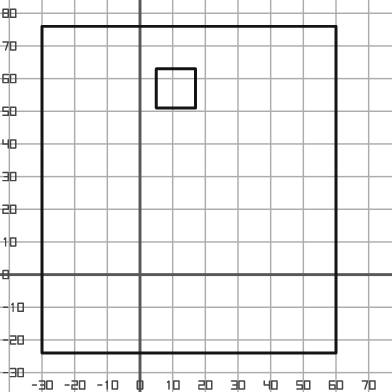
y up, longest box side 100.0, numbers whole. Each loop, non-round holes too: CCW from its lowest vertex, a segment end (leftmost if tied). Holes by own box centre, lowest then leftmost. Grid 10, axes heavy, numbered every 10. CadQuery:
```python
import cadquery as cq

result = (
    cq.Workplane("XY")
    .moveTo(-30.0, -24.0)
    .lineTo(60.0, -24.0)
    .lineTo(60.0, 76.0)
    .lineTo(-30.0, 76.0)
    .close()
    .moveTo(5.0, 51.0)
    .lineTo(17.0, 51.0)
    .lineTo(17.0, 63.0)
    .lineTo(5.0, 63.0)
    .close()
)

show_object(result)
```